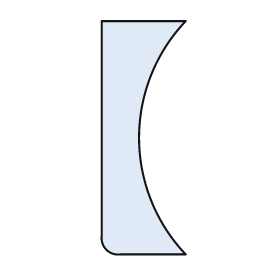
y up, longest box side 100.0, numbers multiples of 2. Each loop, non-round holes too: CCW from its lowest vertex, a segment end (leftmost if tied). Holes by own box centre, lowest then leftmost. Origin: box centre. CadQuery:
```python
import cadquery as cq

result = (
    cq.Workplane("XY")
    .moveTo(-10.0, -50.0)
    .lineTo(18.0, -50.0)
    .threePointArc((-2.0, 0.0), (18.0, 50.0))
    .lineTo(-18.0, 50.0)
    .lineTo(-18.0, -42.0)
    .threePointArc((-16.0, -48.0), (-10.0, -50.0))
    .close()
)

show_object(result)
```